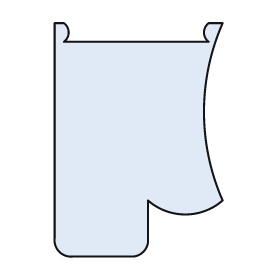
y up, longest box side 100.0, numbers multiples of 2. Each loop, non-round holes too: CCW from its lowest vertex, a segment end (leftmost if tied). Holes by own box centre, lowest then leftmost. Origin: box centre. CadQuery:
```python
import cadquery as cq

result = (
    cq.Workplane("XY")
    .moveTo(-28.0, -50.0)
    .lineTo(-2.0, -50.0)
    .threePointArc((2.0, -48.0), (4.0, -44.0))
    .lineTo(4.0, -26.0)
    .threePointArc((20.0, -32.0), (36.0, -26.0))
    .threePointArc((28.0, 12.0), (36.0, 50.0))
    .lineTo(30.0, 50.0)
    .threePointArc((28.0, 46.0), (30.0, 42.0))
    .lineTo(-32.0, 42.0)
    .threePointArc((-30.0, 46.0), (-32.0, 50.0))
    .lineTo(-36.0, 50.0)
    .lineTo(-36.0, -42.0)
    .threePointArc((-34.0, -48.0), (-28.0, -50.0))
    .close()
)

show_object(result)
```